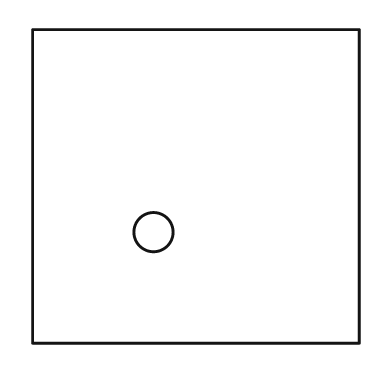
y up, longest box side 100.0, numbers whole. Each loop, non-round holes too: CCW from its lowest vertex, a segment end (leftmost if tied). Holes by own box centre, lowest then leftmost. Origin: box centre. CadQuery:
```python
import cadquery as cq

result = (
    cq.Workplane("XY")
    .moveTo(-50.0, -48.0)
    .lineTo(50.0, -48.0)
    .lineTo(50.0, 48.0)
    .lineTo(-50.0, 48.0)
    .close()
    .moveTo(-13.0, -14.0)
    .circle(6.0)
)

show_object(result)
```